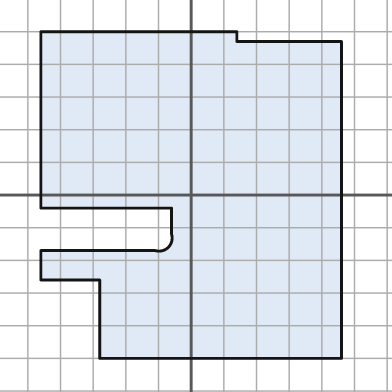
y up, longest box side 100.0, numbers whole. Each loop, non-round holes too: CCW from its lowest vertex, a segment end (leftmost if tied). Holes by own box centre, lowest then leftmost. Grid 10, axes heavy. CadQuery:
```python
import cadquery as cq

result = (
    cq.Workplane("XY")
    .moveTo(-28.0, -50.0)
    .lineTo(46.0, -50.0)
    .lineTo(46.0, 47.0)
    .lineTo(14.0, 47.0)
    .lineTo(14.0, 50.0)
    .lineTo(-46.0, 50.0)
    .lineTo(-46.0, -4.0)
    .lineTo(-6.0, -4.0)
    .lineTo(-6.0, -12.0)
    .threePointArc((-7.0, -16.0), (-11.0, -17.0))
    .lineTo(-46.0, -17.0)
    .lineTo(-46.0, -26.0)
    .lineTo(-28.0, -26.0)
    .close()
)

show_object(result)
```